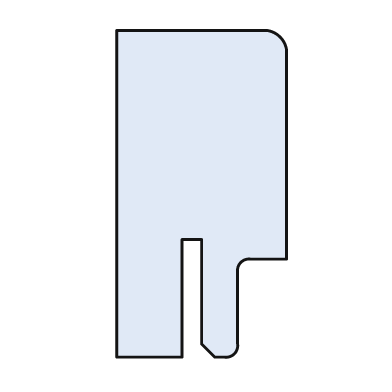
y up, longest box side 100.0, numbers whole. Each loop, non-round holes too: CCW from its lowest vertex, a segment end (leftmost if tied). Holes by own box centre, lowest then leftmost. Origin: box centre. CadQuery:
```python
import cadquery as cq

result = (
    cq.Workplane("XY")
    .moveTo(-26.0, -50.0)
    .lineTo(-6.0, -50.0)
    .lineTo(-6.0, -14.0)
    .lineTo(0.0, -14.0)
    .lineTo(0.0, -46.0)
    .lineTo(4.0, -50.0)
    .lineTo(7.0, -50.0)
    .threePointArc((10.0, -49.0), (11.0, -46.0))
    .lineTo(11.0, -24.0)
    .threePointArc((12.0, -21.0), (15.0, -20.0))
    .lineTo(26.0, -20.0)
    .lineTo(26.0, 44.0)
    .threePointArc((24.0, 48.0), (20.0, 50.0))
    .lineTo(-26.0, 50.0)
    .close()
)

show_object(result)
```